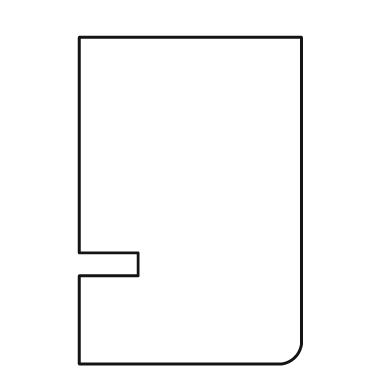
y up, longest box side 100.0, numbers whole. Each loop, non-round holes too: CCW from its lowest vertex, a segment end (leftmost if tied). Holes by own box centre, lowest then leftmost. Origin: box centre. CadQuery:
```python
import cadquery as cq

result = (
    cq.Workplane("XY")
    .moveTo(-34.0, -50.0)
    .lineTo(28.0, -50.0)
    .threePointArc((32.0, -48.0), (34.0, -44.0))
    .lineTo(34.0, 50.0)
    .lineTo(-34.0, 50.0)
    .lineTo(-34.0, -16.0)
    .lineTo(-16.0, -16.0)
    .lineTo(-16.0, -23.0)
    .lineTo(-34.0, -23.0)
    .close()
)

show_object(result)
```